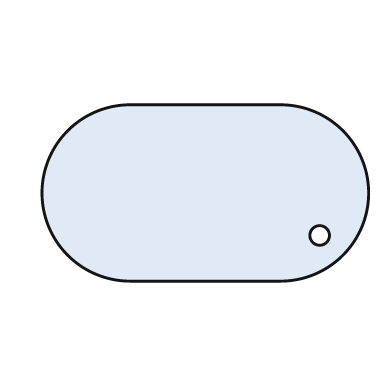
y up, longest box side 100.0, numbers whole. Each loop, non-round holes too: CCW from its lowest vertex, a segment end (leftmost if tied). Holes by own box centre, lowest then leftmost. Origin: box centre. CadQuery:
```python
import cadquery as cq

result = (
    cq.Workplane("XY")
    .moveTo(-23.0, -27.0)
    .lineTo(23.0, -27.0)
    .threePointArc((50.0, 0.0), (23.0, 27.0))
    .lineTo(-23.0, 27.0)
    .threePointArc((-50.0, 0.0), (-23.0, -27.0))
    .close()
    .moveTo(35.0, -13.0)
    .circle(3.0)
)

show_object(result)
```